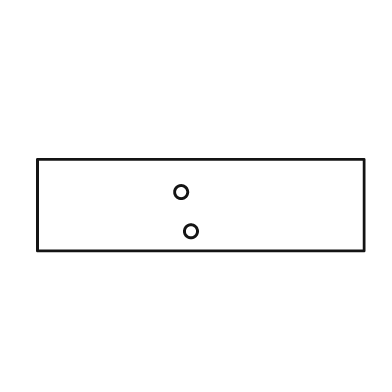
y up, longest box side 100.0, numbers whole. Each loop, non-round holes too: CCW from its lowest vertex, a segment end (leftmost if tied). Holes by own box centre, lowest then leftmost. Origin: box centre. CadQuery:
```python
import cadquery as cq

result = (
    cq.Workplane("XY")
    .moveTo(-50.0, -14.0)
    .lineTo(50.0, -14.0)
    .lineTo(50.0, 14.0)
    .lineTo(-50.0, 14.0)
    .close()
    .moveTo(-3.0, -8.0)
    .circle(2.0)
    .moveTo(-6.0, 4.0)
    .circle(2.0)
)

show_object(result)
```